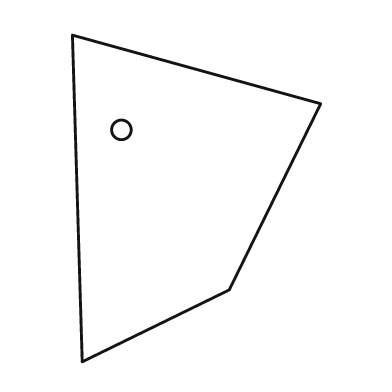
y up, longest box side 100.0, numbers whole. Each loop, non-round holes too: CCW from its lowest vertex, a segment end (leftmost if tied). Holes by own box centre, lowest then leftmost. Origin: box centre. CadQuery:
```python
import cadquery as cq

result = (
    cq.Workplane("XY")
    .moveTo(-35.0, -50.0)
    .lineTo(10.0, -28.0)
    .lineTo(38.0, 29.0)
    .lineTo(-38.0, 50.0)
    .close()
    .moveTo(-23.0, 21.0)
    .circle(3.0)
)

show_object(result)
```